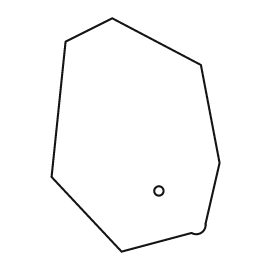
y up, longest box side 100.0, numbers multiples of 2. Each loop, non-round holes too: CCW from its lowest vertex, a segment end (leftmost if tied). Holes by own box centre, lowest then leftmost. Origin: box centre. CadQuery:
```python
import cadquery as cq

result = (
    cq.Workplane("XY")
    .moveTo(-6.0, -50.0)
    .lineTo(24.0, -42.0)
    .threePointArc((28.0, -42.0), (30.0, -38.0))
    .lineTo(36.0, -12.0)
    .lineTo(28.0, 30.0)
    .lineTo(-10.0, 50.0)
    .lineTo(-30.0, 40.0)
    .lineTo(-36.0, -18.0)
    .close()
    .moveTo(10.0, -24.0)
    .circle(2.0)
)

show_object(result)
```